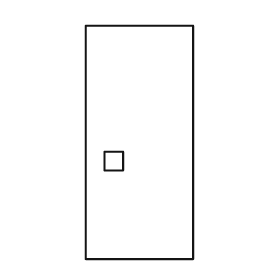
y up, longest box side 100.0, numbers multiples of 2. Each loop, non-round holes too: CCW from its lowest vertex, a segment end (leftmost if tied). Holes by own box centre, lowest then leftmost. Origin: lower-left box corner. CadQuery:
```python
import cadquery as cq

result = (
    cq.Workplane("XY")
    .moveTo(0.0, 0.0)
    .lineTo(46.0, 0.0)
    .lineTo(46.0, 100.0)
    .lineTo(0.0, 100.0)
    .close()
    .moveTo(8.0, 38.0)
    .lineTo(16.0, 38.0)
    .lineTo(16.0, 46.0)
    .lineTo(8.0, 46.0)
    .close()
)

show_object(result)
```